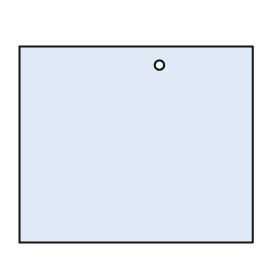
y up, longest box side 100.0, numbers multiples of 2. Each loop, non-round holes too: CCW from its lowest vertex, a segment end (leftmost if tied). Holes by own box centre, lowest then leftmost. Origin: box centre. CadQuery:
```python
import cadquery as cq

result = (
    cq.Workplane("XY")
    .moveTo(-50.0, -42.0)
    .lineTo(50.0, -42.0)
    .lineTo(50.0, 42.0)
    .lineTo(-50.0, 42.0)
    .close()
    .moveTo(10.0, 34.0)
    .circle(2.0)
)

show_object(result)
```